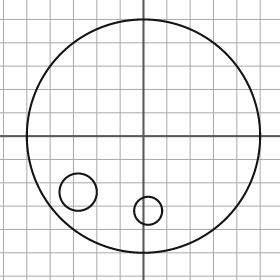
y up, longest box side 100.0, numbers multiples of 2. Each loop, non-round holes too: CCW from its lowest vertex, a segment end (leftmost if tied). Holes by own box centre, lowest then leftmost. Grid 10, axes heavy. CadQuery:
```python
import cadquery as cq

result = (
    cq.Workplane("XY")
    .moveTo(0.0, 0.0)
    .circle(50.0)
    .moveTo(2.0, -32.0)
    .circle(6.0)
    .moveTo(-28.0, -24.0)
    .circle(8.0)
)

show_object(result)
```